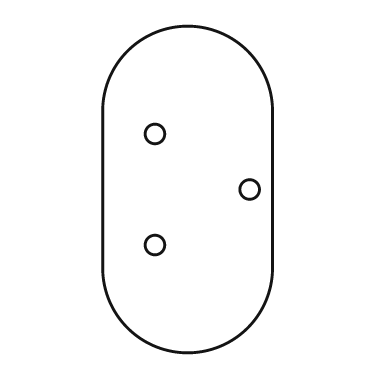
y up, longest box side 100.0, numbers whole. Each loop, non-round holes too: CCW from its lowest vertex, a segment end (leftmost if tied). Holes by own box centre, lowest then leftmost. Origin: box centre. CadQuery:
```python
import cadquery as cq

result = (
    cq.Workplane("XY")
    .moveTo(-26.0, -24.0)
    .threePointArc((0.0, -50.0), (26.0, -24.0))
    .lineTo(26.0, 24.0)
    .threePointArc((0.0, 50.0), (-26.0, 24.0))
    .close()
    .moveTo(-10.0, -17.0)
    .circle(3.0)
    .moveTo(19.0, 0.0)
    .circle(3.0)
    .moveTo(-10.0, 17.0)
    .circle(3.0)
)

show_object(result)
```